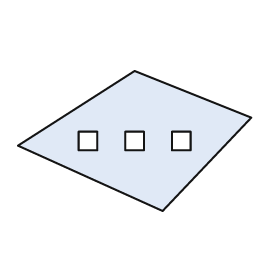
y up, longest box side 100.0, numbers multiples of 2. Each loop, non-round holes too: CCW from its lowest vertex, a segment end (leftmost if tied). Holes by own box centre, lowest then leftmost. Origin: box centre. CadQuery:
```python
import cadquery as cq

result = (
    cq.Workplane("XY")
    .moveTo(12.0, -30.0)
    .lineTo(50.0, 10.0)
    .lineTo(0.0, 30.0)
    .lineTo(-50.0, -2.0)
    .close()
    .moveTo(-24.0, -4.0)
    .lineTo(-16.0, -4.0)
    .lineTo(-16.0, 4.0)
    .lineTo(-24.0, 4.0)
    .close()
    .moveTo(-4.0, -4.0)
    .lineTo(4.0, -4.0)
    .lineTo(4.0, 4.0)
    .lineTo(-4.0, 4.0)
    .close()
    .moveTo(16.0, -4.0)
    .lineTo(24.0, -4.0)
    .lineTo(24.0, 4.0)
    .lineTo(16.0, 4.0)
    .close()
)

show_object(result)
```